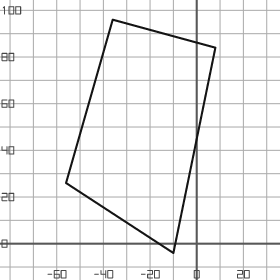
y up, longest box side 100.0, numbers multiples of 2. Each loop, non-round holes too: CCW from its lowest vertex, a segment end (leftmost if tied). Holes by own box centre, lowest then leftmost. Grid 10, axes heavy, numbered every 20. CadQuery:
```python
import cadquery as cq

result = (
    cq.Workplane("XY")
    .moveTo(-10.0, -4.0)
    .lineTo(8.0, 84.0)
    .lineTo(-36.0, 96.0)
    .lineTo(-56.0, 26.0)
    .close()
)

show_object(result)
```